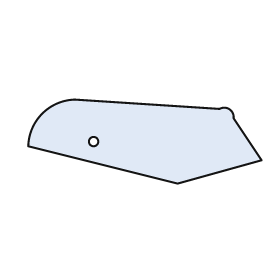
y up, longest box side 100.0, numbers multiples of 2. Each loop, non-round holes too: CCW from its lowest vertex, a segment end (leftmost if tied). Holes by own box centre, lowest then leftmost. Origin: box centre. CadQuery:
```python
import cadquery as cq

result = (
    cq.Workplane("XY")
    .moveTo(14.0, -18.0)
    .lineTo(50.0, -8.0)
    .lineTo(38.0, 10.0)
    .threePointArc((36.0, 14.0), (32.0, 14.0))
    .lineTo(-30.0, 18.0)
    .threePointArc((-44.0, 12.0), (-50.0, -2.0))
    .close()
    .moveTo(-22.0, 0.0)
    .circle(2.0)
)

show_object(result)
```